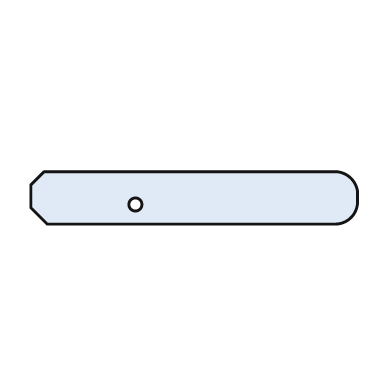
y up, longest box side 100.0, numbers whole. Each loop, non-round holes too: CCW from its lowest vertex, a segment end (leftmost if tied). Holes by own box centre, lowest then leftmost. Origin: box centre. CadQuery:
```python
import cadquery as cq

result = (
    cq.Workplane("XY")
    .moveTo(-45.0, -8.0)
    .lineTo(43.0, -8.0)
    .threePointArc((48.0, -6.0), (50.0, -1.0))
    .lineTo(50.0, 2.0)
    .threePointArc((48.0, 6.0), (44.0, 8.0))
    .lineTo(-46.0, 8.0)
    .lineTo(-50.0, 4.0)
    .lineTo(-50.0, -3.0)
    .close()
    .moveTo(-18.0, -2.0)
    .circle(2.0)
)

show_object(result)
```